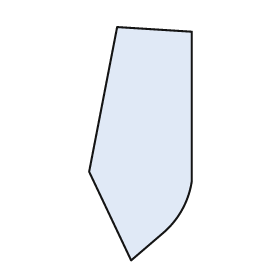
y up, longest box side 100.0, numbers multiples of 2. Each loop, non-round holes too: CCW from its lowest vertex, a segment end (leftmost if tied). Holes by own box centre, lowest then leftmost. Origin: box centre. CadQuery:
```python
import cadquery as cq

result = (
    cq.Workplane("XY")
    .moveTo(-4.0, -50.0)
    .lineTo(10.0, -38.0)
    .threePointArc((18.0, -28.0), (22.0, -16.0))
    .lineTo(22.0, 48.0)
    .lineTo(-10.0, 50.0)
    .lineTo(-22.0, -12.0)
    .close()
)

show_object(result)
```